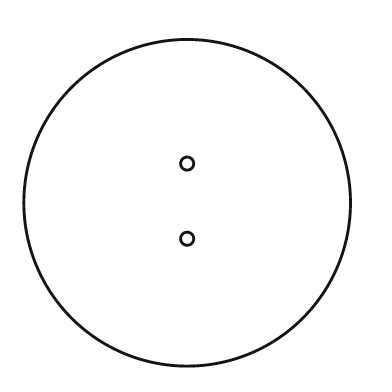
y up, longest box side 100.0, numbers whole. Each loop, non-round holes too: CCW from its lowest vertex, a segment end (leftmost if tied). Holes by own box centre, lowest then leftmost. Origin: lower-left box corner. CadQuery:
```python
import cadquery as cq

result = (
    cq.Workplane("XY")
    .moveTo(50.0, 50.0)
    .circle(50.0)
    .moveTo(50.0, 39.0)
    .circle(2.0)
    .moveTo(50.0, 62.0)
    .circle(2.0)
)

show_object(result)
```